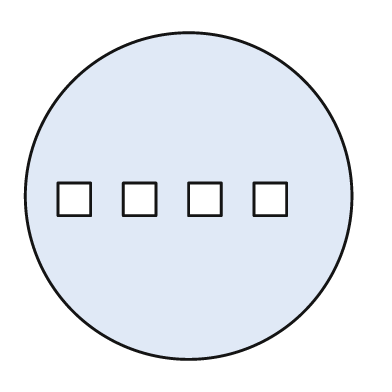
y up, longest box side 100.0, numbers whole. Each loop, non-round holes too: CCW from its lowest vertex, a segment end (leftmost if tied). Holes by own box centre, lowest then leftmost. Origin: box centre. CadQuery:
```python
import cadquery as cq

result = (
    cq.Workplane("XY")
    .moveTo(0.0, 0.0)
    .circle(50.0)
    .moveTo(-40.0, -6.0)
    .lineTo(-30.0, -6.0)
    .lineTo(-30.0, 4.0)
    .lineTo(-40.0, 4.0)
    .close()
    .moveTo(-20.0, -6.0)
    .lineTo(-10.0, -6.0)
    .lineTo(-10.0, 4.0)
    .lineTo(-20.0, 4.0)
    .close()
    .moveTo(0.0, -6.0)
    .lineTo(10.0, -6.0)
    .lineTo(10.0, 4.0)
    .lineTo(0.0, 4.0)
    .close()
    .moveTo(20.0, -6.0)
    .lineTo(30.0, -6.0)
    .lineTo(30.0, 4.0)
    .lineTo(20.0, 4.0)
    .close()
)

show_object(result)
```